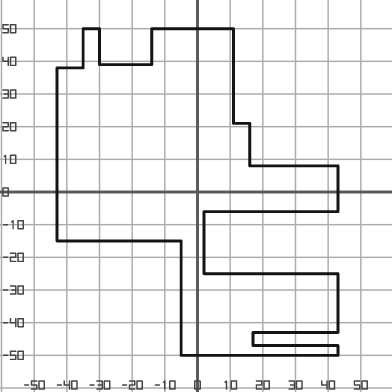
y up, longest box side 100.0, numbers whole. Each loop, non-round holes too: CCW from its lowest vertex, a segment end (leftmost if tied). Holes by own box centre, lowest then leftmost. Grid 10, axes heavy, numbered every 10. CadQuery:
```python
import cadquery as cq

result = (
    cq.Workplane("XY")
    .moveTo(-5.0, -50.0)
    .lineTo(43.0, -50.0)
    .lineTo(43.0, -47.0)
    .lineTo(17.0, -47.0)
    .lineTo(17.0, -43.0)
    .lineTo(43.0, -43.0)
    .lineTo(43.0, -25.0)
    .lineTo(2.0, -25.0)
    .lineTo(2.0, -6.0)
    .lineTo(43.0, -6.0)
    .lineTo(43.0, 8.0)
    .lineTo(16.0, 8.0)
    .lineTo(16.0, 21.0)
    .lineTo(11.0, 21.0)
    .lineTo(11.0, 50.0)
    .lineTo(-14.0, 50.0)
    .lineTo(-14.0, 39.0)
    .lineTo(-30.0, 39.0)
    .lineTo(-30.0, 50.0)
    .lineTo(-35.0, 50.0)
    .lineTo(-35.0, 38.0)
    .lineTo(-43.0, 38.0)
    .lineTo(-43.0, -15.0)
    .lineTo(-5.0, -15.0)
    .close()
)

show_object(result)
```